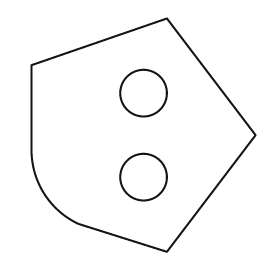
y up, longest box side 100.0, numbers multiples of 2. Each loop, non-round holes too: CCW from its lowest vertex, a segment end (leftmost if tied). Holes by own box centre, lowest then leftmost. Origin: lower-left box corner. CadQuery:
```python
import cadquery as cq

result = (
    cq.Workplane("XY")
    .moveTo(58.0, 0.0)
    .lineTo(96.0, 50.0)
    .lineTo(58.0, 100.0)
    .lineTo(0.0, 80.0)
    .lineTo(0.0, 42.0)
    .threePointArc((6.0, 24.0), (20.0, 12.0))
    .close()
    .moveTo(48.0, 32.0)
    .circle(10.0)
    .moveTo(48.0, 68.0)
    .circle(10.0)
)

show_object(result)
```